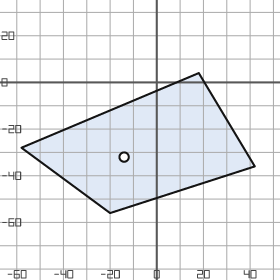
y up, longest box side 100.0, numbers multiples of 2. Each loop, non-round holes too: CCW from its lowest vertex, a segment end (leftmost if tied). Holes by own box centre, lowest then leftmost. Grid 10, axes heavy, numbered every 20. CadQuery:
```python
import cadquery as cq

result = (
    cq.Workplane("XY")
    .moveTo(-20.0, -56.0)
    .lineTo(42.0, -36.0)
    .lineTo(18.0, 4.0)
    .lineTo(-58.0, -28.0)
    .close()
    .moveTo(-14.0, -32.0)
    .circle(2.0)
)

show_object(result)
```